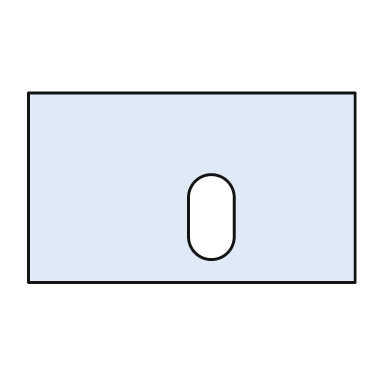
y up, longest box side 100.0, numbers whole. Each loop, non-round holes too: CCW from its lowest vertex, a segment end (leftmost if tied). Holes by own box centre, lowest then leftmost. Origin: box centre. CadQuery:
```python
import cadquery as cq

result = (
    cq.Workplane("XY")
    .moveTo(-50.0, -29.0)
    .lineTo(50.0, -29.0)
    .lineTo(50.0, 29.0)
    .lineTo(-50.0, 29.0)
    .close()
    .moveTo(-1.0, -15.0)
    .threePointArc((6.0, -22.0), (13.0, -15.0))
    .lineTo(13.0, -3.0)
    .threePointArc((6.0, 4.0), (-1.0, -3.0))
    .close()
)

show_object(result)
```